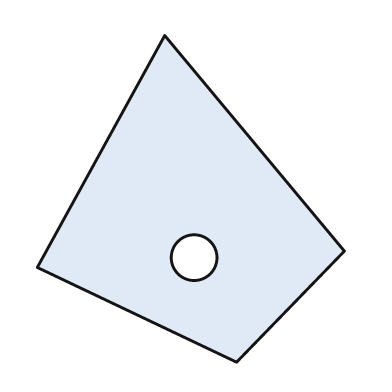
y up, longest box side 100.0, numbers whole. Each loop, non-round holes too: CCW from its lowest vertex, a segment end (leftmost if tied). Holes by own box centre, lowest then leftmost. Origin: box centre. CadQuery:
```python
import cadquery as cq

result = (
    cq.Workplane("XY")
    .moveTo(14.0, -50.0)
    .lineTo(47.0, -16.0)
    .lineTo(-8.0, 50.0)
    .lineTo(-47.0, -21.0)
    .close()
    .moveTo(1.0, -18.0)
    .circle(7.0)
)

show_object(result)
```